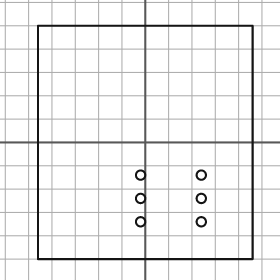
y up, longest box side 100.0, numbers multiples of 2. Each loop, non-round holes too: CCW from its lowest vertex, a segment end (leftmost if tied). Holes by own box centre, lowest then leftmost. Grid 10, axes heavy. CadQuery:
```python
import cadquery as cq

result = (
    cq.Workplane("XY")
    .moveTo(-46.0, -50.0)
    .lineTo(46.0, -50.0)
    .lineTo(46.0, 50.0)
    .lineTo(-46.0, 50.0)
    .close()
    .moveTo(-2.0, -34.0)
    .circle(2.0)
    .moveTo(24.0, -34.0)
    .circle(2.0)
    .moveTo(-2.0, -24.0)
    .circle(2.0)
    .moveTo(24.0, -24.0)
    .circle(2.0)
    .moveTo(-2.0, -14.0)
    .circle(2.0)
    .moveTo(24.0, -14.0)
    .circle(2.0)
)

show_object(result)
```